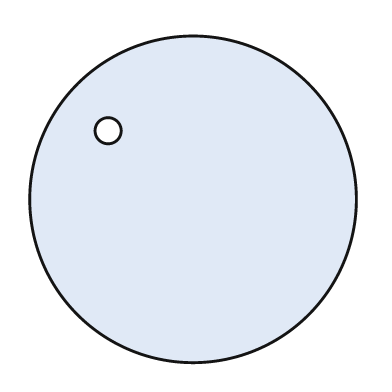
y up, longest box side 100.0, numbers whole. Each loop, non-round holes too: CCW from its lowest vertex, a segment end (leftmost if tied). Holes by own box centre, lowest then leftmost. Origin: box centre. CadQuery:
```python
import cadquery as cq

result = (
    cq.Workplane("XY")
    .moveTo(0.0, 0.0)
    .circle(50.0)
    .moveTo(-26.0, 21.0)
    .circle(4.0)
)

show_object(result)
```